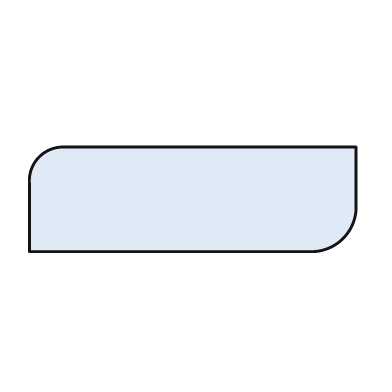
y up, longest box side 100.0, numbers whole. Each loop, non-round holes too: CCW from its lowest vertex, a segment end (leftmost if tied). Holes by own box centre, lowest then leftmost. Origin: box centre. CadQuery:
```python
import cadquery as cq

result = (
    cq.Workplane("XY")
    .moveTo(-50.0, -16.0)
    .lineTo(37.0, -16.0)
    .threePointArc((46.0, -12.0), (50.0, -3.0))
    .lineTo(50.0, 16.0)
    .lineTo(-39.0, 16.0)
    .threePointArc((-47.0, 13.0), (-50.0, 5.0))
    .close()
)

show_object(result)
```